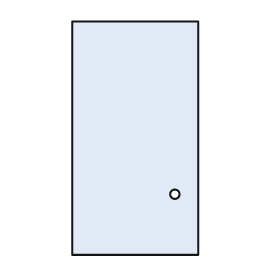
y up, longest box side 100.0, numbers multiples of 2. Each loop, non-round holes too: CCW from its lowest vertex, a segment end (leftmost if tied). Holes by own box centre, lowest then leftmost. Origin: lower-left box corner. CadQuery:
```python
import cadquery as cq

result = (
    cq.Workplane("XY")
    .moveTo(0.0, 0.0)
    .lineTo(54.0, 0.0)
    .lineTo(54.0, 100.0)
    .lineTo(0.0, 100.0)
    .close()
    .moveTo(44.0, 26.0)
    .circle(2.0)
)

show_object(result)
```